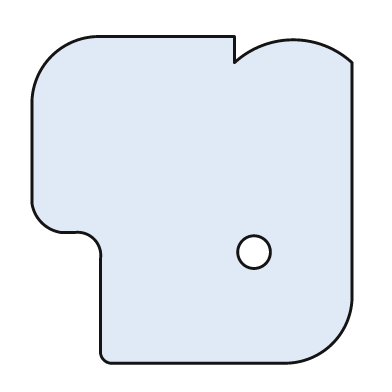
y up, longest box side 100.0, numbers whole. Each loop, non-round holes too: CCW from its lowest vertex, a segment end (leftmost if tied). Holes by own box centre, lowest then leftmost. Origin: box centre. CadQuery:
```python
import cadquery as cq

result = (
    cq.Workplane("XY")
    .moveTo(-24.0, -50.0)
    .lineTo(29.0, -50.0)
    .threePointArc((43.0, -44.0), (49.0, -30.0))
    .lineTo(49.0, 42.0)
    .threePointArc((31.0, 49.0), (13.0, 42.0))
    .lineTo(13.0, 50.0)
    .lineTo(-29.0, 50.0)
    .threePointArc((-43.0, 44.0), (-49.0, 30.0))
    .lineTo(-49.0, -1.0)
    .threePointArc((-46.0, -7.0), (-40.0, -10.0))
    .lineTo(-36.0, -10.0)
    .threePointArc((-30.0, -12.0), (-28.0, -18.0))
    .lineTo(-28.0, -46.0)
    .threePointArc((-27.0, -49.0), (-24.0, -50.0))
    .close()
    .moveTo(19.0, -16.0)
    .circle(5.0)
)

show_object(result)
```